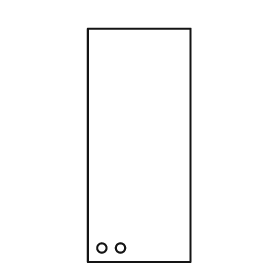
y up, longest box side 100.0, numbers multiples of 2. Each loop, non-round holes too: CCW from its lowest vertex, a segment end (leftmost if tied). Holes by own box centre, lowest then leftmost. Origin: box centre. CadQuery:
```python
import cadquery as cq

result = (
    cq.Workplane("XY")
    .moveTo(-22.0, -50.0)
    .lineTo(22.0, -50.0)
    .lineTo(22.0, 50.0)
    .lineTo(-22.0, 50.0)
    .close()
    .moveTo(-16.0, -44.0)
    .circle(2.0)
    .moveTo(-8.0, -44.0)
    .circle(2.0)
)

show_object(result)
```